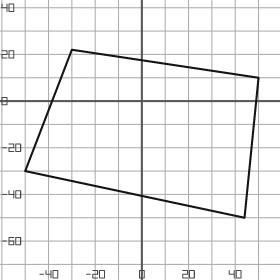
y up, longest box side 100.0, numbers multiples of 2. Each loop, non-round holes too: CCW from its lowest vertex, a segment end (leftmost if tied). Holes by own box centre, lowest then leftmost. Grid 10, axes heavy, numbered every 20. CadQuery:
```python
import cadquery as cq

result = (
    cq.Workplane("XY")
    .moveTo(44.0, -50.0)
    .lineTo(50.0, 10.0)
    .lineTo(-30.0, 22.0)
    .lineTo(-50.0, -30.0)
    .close()
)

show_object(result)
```